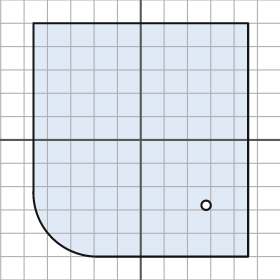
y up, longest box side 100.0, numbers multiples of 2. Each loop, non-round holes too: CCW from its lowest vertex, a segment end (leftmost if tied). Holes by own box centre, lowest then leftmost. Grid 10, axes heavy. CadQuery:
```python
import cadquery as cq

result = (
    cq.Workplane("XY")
    .moveTo(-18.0, -50.0)
    .lineTo(46.0, -50.0)
    .lineTo(46.0, 50.0)
    .lineTo(-46.0, 50.0)
    .lineTo(-46.0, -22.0)
    .threePointArc((-38.0, -42.0), (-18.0, -50.0))
    .close()
    .moveTo(28.0, -28.0)
    .circle(2.0)
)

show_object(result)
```